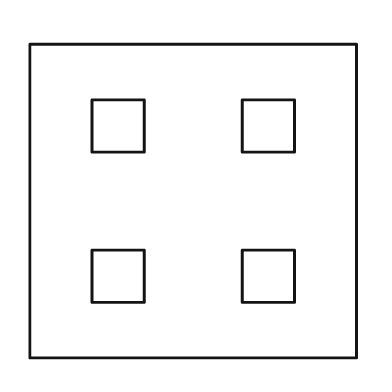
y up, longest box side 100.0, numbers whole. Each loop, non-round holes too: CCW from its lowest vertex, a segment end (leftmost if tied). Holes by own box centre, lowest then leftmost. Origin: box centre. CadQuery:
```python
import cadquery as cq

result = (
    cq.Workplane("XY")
    .moveTo(-50.0, -48.0)
    .lineTo(50.0, -48.0)
    .lineTo(50.0, 48.0)
    .lineTo(-50.0, 48.0)
    .close()
    .moveTo(-31.0, -31.0)
    .lineTo(-15.0, -31.0)
    .lineTo(-15.0, -15.0)
    .lineTo(-31.0, -15.0)
    .close()
    .moveTo(15.0, -31.0)
    .lineTo(31.0, -31.0)
    .lineTo(31.0, -15.0)
    .lineTo(15.0, -15.0)
    .close()
    .moveTo(-31.0, 15.0)
    .lineTo(-15.0, 15.0)
    .lineTo(-15.0, 31.0)
    .lineTo(-31.0, 31.0)
    .close()
    .moveTo(15.0, 15.0)
    .lineTo(31.0, 15.0)
    .lineTo(31.0, 31.0)
    .lineTo(15.0, 31.0)
    .close()
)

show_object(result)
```